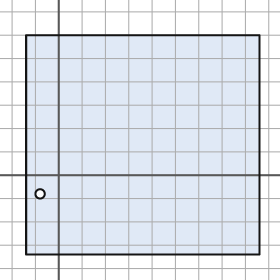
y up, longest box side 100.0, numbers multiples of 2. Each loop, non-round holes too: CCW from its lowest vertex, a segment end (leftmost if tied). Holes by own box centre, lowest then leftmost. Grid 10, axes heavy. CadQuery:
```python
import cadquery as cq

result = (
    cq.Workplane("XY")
    .moveTo(-14.0, -34.0)
    .lineTo(86.0, -34.0)
    .lineTo(86.0, 60.0)
    .lineTo(-14.0, 60.0)
    .close()
    .moveTo(-8.0, -8.0)
    .circle(2.0)
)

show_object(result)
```